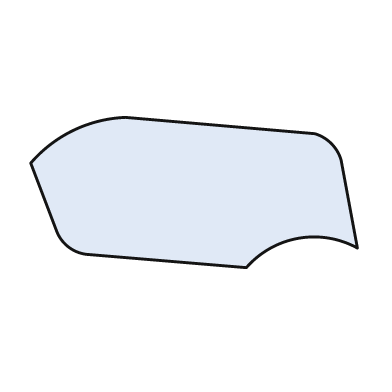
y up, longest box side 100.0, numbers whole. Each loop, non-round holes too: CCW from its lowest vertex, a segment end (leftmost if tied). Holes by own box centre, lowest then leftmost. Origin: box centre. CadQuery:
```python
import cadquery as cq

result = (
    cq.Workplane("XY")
    .moveTo(16.0, -23.0)
    .threePointArc((32.0, -14.0), (50.0, -17.0))
    .lineTo(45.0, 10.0)
    .threePointArc((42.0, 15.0), (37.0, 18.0))
    .lineTo(-21.0, 23.0)
    .threePointArc((-37.0, 19.0), (-50.0, 9.0))
    .lineTo(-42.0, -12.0)
    .threePointArc((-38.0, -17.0), (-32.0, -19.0))
    .close()
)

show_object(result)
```